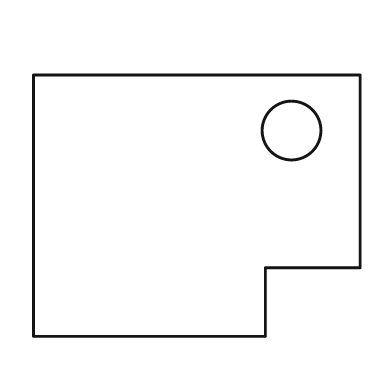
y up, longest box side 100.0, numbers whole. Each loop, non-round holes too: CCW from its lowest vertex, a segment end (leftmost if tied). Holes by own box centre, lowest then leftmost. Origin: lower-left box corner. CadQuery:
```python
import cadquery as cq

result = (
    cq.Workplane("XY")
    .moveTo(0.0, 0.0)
    .lineTo(71.0, 0.0)
    .lineTo(71.0, 21.0)
    .lineTo(100.0, 21.0)
    .lineTo(100.0, 80.0)
    .lineTo(0.0, 80.0)
    .close()
    .moveTo(79.0, 63.0)
    .circle(9.0)
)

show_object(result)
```